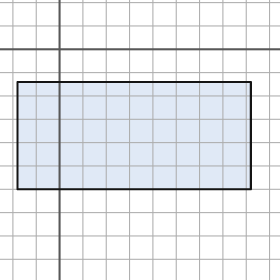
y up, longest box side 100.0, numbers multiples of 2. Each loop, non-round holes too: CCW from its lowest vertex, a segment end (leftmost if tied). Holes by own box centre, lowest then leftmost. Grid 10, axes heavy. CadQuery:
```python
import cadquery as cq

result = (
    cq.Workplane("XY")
    .moveTo(-18.0, -60.0)
    .lineTo(82.0, -60.0)
    .lineTo(82.0, -14.0)
    .lineTo(-18.0, -14.0)
    .close()
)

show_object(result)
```